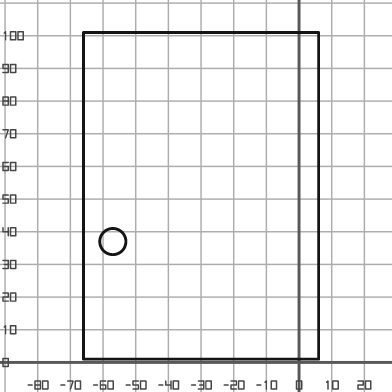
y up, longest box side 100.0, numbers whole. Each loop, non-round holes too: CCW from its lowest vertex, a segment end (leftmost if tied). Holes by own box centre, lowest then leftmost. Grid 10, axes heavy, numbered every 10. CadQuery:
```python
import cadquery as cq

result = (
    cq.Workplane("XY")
    .moveTo(-66.0, 1.0)
    .lineTo(6.0, 1.0)
    .lineTo(6.0, 101.0)
    .lineTo(-66.0, 101.0)
    .close()
    .moveTo(-57.0, 37.0)
    .circle(4.0)
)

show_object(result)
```